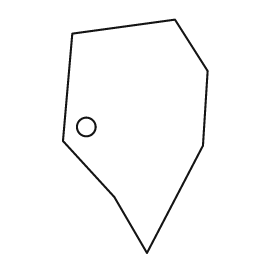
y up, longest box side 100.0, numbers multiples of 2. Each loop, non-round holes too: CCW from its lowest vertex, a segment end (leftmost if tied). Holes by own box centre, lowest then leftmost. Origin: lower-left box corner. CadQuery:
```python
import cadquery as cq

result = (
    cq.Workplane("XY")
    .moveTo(36.0, 0.0)
    .lineTo(60.0, 46.0)
    .lineTo(62.0, 78.0)
    .lineTo(48.0, 100.0)
    .lineTo(4.0, 94.0)
    .lineTo(0.0, 48.0)
    .lineTo(22.0, 24.0)
    .close()
    .moveTo(10.0, 54.0)
    .circle(4.0)
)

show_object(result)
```